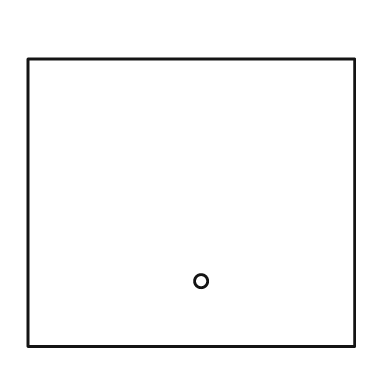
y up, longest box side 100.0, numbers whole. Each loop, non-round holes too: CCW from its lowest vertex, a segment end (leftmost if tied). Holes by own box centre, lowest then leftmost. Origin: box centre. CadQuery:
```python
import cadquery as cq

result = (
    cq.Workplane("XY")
    .moveTo(-50.0, -44.0)
    .lineTo(50.0, -44.0)
    .lineTo(50.0, 44.0)
    .lineTo(-50.0, 44.0)
    .close()
    .moveTo(3.0, -24.0)
    .circle(2.0)
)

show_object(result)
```